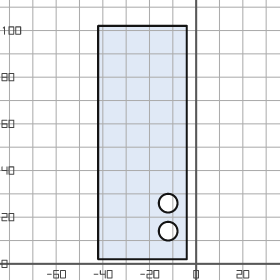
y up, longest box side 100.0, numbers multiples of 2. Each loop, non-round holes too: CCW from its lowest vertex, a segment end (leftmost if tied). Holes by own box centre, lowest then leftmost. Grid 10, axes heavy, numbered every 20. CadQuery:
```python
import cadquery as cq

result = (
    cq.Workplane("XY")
    .moveTo(-42.0, 2.0)
    .lineTo(-4.0, 2.0)
    .lineTo(-4.0, 102.0)
    .lineTo(-42.0, 102.0)
    .close()
    .moveTo(-12.0, 14.0)
    .circle(4.0)
    .moveTo(-12.0, 26.0)
    .circle(4.0)
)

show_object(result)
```